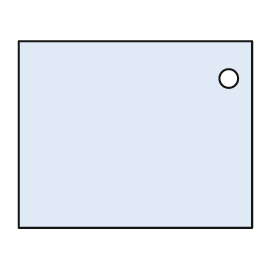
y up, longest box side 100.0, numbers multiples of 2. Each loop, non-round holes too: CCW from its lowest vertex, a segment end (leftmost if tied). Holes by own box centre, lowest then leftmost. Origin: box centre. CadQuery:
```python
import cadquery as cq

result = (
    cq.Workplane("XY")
    .moveTo(-50.0, -40.0)
    .lineTo(50.0, -40.0)
    .lineTo(50.0, 40.0)
    .lineTo(-50.0, 40.0)
    .close()
    .moveTo(40.0, 24.0)
    .circle(4.0)
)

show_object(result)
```